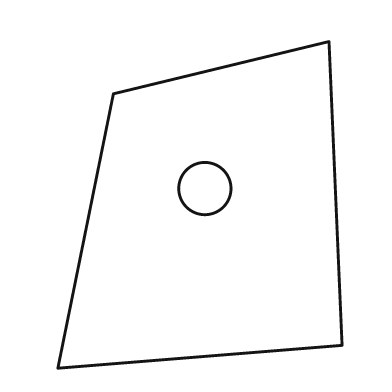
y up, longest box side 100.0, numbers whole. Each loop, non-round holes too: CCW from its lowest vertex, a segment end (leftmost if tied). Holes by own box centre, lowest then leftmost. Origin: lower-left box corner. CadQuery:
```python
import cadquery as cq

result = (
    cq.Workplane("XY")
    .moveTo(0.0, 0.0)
    .lineTo(87.0, 7.0)
    .lineTo(83.0, 100.0)
    .lineTo(17.0, 84.0)
    .close()
    .moveTo(45.0, 55.0)
    .circle(8.0)
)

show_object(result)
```